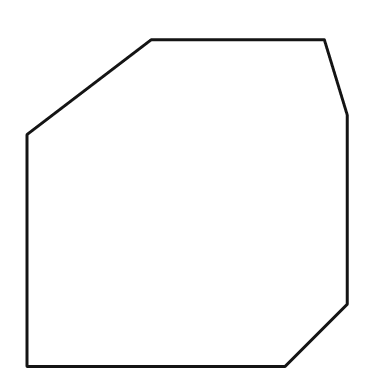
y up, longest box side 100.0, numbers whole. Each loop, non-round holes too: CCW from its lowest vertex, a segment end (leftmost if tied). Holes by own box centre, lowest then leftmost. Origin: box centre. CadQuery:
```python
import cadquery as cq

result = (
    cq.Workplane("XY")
    .moveTo(-49.0, -50.0)
    .lineTo(30.0, -50.0)
    .lineTo(49.0, -31.0)
    .lineTo(49.0, 27.0)
    .lineTo(42.0, 50.0)
    .lineTo(-11.0, 50.0)
    .lineTo(-49.0, 21.0)
    .close()
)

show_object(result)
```